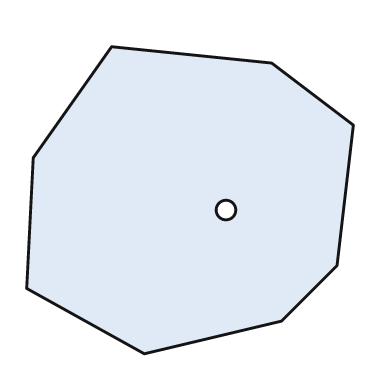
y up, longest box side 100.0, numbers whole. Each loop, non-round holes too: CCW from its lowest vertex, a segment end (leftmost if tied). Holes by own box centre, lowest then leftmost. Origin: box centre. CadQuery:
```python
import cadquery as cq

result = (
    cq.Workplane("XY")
    .moveTo(-14.0, -47.0)
    .lineTo(28.0, -37.0)
    .lineTo(45.0, -20.0)
    .lineTo(50.0, 23.0)
    .lineTo(25.0, 42.0)
    .lineTo(-24.0, 47.0)
    .lineTo(-48.0, 13.0)
    .lineTo(-50.0, -27.0)
    .close()
    .moveTo(11.0, -3.0)
    .circle(3.0)
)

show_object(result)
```